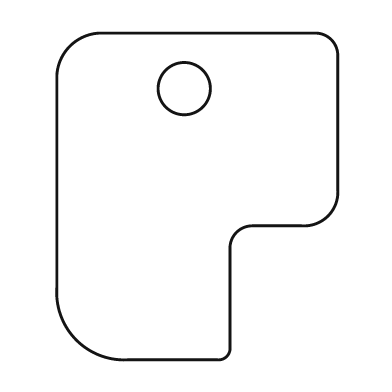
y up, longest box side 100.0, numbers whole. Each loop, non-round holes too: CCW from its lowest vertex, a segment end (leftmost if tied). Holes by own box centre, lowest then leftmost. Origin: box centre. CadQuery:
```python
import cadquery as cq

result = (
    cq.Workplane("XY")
    .moveTo(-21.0, -50.0)
    .lineTo(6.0, -50.0)
    .threePointArc((9.0, -49.0), (10.0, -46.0))
    .lineTo(10.0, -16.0)
    .threePointArc((12.0, -11.0), (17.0, -9.0))
    .lineTo(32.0, -9.0)
    .threePointArc((40.0, -6.0), (43.0, 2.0))
    .lineTo(43.0, 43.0)
    .threePointArc((41.0, 48.0), (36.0, 50.0))
    .lineTo(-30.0, 50.0)
    .threePointArc((-39.0, 46.0), (-43.0, 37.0))
    .lineTo(-43.0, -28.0)
    .threePointArc((-37.0, -44.0), (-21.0, -50.0))
    .close()
    .moveTo(-4.0, 33.0)
    .circle(8.0)
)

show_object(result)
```